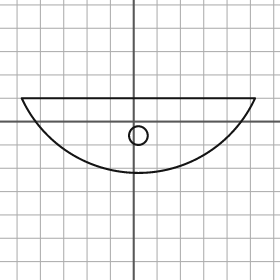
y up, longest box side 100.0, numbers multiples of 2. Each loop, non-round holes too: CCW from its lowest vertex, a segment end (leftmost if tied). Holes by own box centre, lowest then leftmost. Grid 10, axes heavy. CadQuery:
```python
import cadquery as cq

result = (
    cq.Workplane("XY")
    .moveTo(-48.0, 10.0)
    .threePointArc((2.0, -22.0), (52.0, 10.0))
    .close()
    .moveTo(2.0, -6.0)
    .circle(4.0)
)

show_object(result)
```